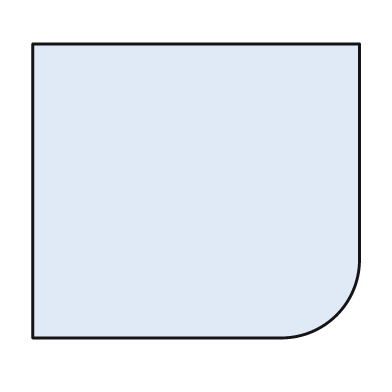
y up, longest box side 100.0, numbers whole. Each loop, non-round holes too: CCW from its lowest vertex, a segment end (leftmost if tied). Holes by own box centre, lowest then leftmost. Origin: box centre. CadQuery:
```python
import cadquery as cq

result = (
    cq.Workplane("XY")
    .moveTo(-50.0, -45.0)
    .lineTo(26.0, -45.0)
    .threePointArc((43.0, -38.0), (50.0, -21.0))
    .lineTo(50.0, 45.0)
    .lineTo(-50.0, 45.0)
    .close()
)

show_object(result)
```